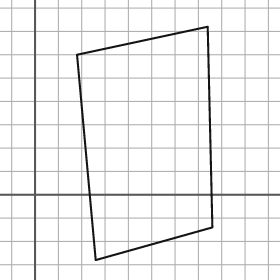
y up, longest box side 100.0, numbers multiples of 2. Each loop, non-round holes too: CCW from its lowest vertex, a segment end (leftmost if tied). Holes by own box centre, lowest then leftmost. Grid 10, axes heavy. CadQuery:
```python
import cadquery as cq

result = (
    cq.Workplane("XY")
    .moveTo(26.0, -28.0)
    .lineTo(76.0, -14.0)
    .lineTo(74.0, 72.0)
    .lineTo(18.0, 60.0)
    .close()
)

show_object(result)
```